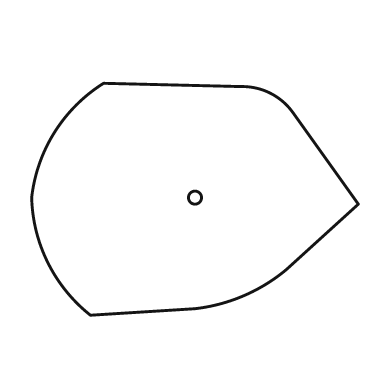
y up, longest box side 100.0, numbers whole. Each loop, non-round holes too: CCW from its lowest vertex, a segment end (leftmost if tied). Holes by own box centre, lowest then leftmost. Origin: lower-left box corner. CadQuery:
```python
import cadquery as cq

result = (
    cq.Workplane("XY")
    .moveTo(18.0, 0.0)
    .lineTo(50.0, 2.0)
    .threePointArc((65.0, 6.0), (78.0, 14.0))
    .lineTo(100.0, 34.0)
    .lineTo(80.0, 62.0)
    .threePointArc((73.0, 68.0), (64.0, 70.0))
    .lineTo(22.0, 71.0)
    .threePointArc((7.0, 56.0), (0.0, 36.0))
    .threePointArc((5.0, 16.0), (18.0, 0.0))
    .close()
    .moveTo(50.0, 36.0)
    .circle(2.0)
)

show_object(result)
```